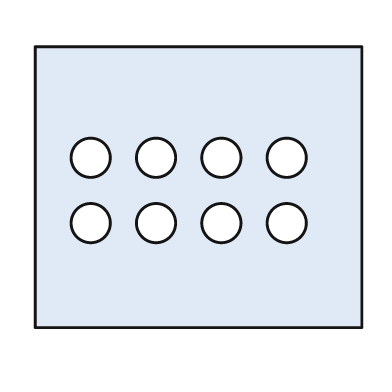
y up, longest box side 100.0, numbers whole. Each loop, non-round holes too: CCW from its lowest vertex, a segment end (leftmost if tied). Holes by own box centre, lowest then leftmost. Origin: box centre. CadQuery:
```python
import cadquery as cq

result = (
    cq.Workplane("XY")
    .moveTo(-50.0, -43.0)
    .lineTo(50.0, -43.0)
    .lineTo(50.0, 43.0)
    .lineTo(-50.0, 43.0)
    .close()
    .moveTo(-33.0, -11.0)
    .circle(6.0)
    .moveTo(-13.0, -11.0)
    .circle(6.0)
    .moveTo(7.0, -11.0)
    .circle(6.0)
    .moveTo(27.0, -11.0)
    .circle(6.0)
    .moveTo(-33.0, 9.0)
    .circle(6.0)
    .moveTo(-13.0, 9.0)
    .circle(6.0)
    .moveTo(7.0, 9.0)
    .circle(6.0)
    .moveTo(27.0, 9.0)
    .circle(6.0)
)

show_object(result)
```